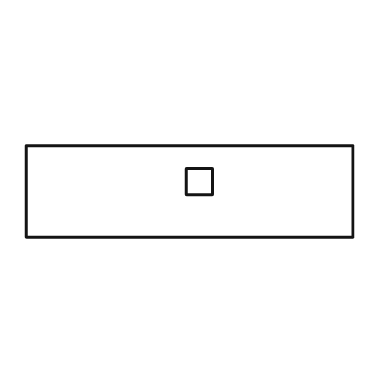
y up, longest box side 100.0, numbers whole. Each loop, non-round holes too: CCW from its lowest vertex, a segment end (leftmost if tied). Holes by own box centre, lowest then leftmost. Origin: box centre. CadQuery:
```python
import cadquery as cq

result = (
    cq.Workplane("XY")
    .moveTo(-50.0, -14.0)
    .lineTo(50.0, -14.0)
    .lineTo(50.0, 14.0)
    .lineTo(-50.0, 14.0)
    .close()
    .moveTo(-1.0, -1.0)
    .lineTo(7.0, -1.0)
    .lineTo(7.0, 7.0)
    .lineTo(-1.0, 7.0)
    .close()
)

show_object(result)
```